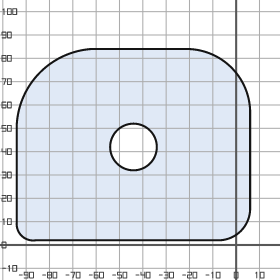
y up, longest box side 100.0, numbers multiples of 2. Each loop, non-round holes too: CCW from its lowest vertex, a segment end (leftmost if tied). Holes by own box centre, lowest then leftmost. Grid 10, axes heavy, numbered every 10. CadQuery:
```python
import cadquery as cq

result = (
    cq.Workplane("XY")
    .moveTo(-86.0, 2.0)
    .lineTo(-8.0, 2.0)
    .threePointArc((2.0, 6.0), (6.0, 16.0))
    .lineTo(6.0, 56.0)
    .threePointArc((-2.0, 76.0), (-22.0, 84.0))
    .lineTo(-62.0, 84.0)
    .threePointArc((-84.0, 74.0), (-94.0, 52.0))
    .lineTo(-94.0, 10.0)
    .threePointArc((-92.0, 4.0), (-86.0, 2.0))
    .close()
    .moveTo(-44.0, 42.0)
    .circle(10.0)
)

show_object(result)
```